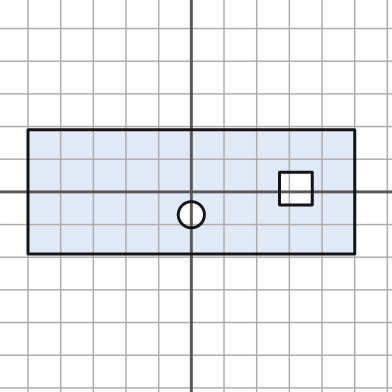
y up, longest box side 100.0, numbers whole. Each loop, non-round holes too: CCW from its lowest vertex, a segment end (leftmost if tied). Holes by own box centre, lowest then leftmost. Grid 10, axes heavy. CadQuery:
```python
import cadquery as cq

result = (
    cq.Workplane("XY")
    .moveTo(-50.0, -19.0)
    .lineTo(50.0, -19.0)
    .lineTo(50.0, 19.0)
    .lineTo(-50.0, 19.0)
    .close()
    .moveTo(0.0, -7.0)
    .circle(4.0)
    .moveTo(27.0, -4.0)
    .lineTo(37.0, -4.0)
    .lineTo(37.0, 6.0)
    .lineTo(27.0, 6.0)
    .close()
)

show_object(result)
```